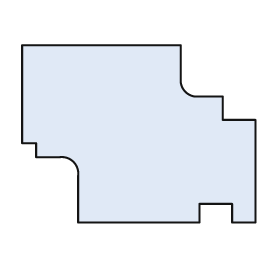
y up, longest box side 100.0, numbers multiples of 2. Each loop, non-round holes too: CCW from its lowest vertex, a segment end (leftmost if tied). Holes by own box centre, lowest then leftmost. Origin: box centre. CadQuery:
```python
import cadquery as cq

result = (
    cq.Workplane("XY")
    .moveTo(-26.0, -38.0)
    .lineTo(26.0, -38.0)
    .lineTo(26.0, -30.0)
    .lineTo(40.0, -30.0)
    .lineTo(40.0, -38.0)
    .lineTo(50.0, -38.0)
    .lineTo(50.0, 6.0)
    .lineTo(36.0, 6.0)
    .lineTo(36.0, 16.0)
    .lineTo(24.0, 16.0)
    .threePointArc((20.0, 18.0), (18.0, 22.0))
    .lineTo(18.0, 38.0)
    .lineTo(-50.0, 38.0)
    .lineTo(-50.0, -4.0)
    .lineTo(-44.0, -4.0)
    .lineTo(-44.0, -10.0)
    .lineTo(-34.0, -10.0)
    .threePointArc((-28.0, -12.0), (-26.0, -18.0))
    .close()
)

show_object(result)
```